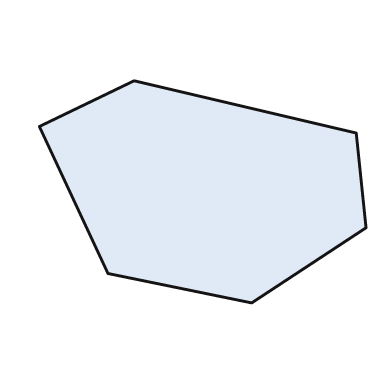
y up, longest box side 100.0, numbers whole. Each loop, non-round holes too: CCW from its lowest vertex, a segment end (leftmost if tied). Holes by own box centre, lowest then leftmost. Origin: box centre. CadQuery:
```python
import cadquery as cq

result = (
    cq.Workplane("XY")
    .moveTo(15.0, -34.0)
    .lineTo(50.0, -11.0)
    .lineTo(47.0, 18.0)
    .lineTo(-21.0, 34.0)
    .lineTo(-50.0, 20.0)
    .lineTo(-29.0, -25.0)
    .close()
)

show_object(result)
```